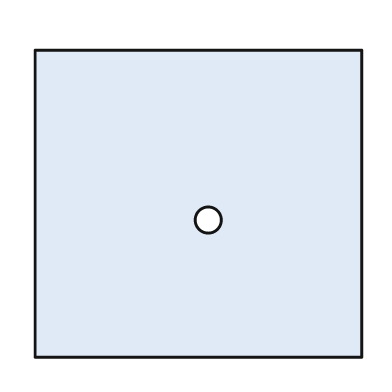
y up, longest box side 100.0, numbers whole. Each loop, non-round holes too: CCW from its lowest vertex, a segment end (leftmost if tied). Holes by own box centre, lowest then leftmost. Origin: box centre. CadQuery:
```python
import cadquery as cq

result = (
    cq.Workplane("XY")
    .moveTo(-50.0, -47.0)
    .lineTo(50.0, -47.0)
    .lineTo(50.0, 47.0)
    .lineTo(-50.0, 47.0)
    .close()
    .moveTo(3.0, -5.0)
    .circle(4.0)
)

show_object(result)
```